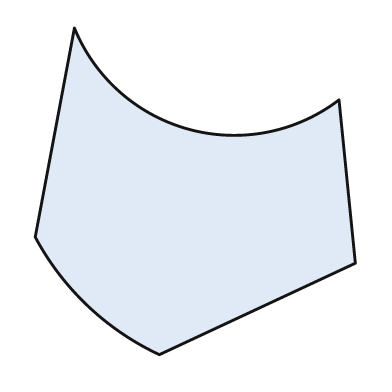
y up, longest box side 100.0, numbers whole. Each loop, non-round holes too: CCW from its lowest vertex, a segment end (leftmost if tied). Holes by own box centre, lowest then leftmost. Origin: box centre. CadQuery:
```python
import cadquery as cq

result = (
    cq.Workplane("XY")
    .moveTo(-11.0, -50.0)
    .lineTo(49.0, -22.0)
    .lineTo(44.0, 28.0)
    .threePointArc((-2.0, 19.0), (-37.0, 50.0))
    .lineTo(-49.0, -14.0)
    .threePointArc((-33.0, -35.0), (-11.0, -50.0))
    .close()
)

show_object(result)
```